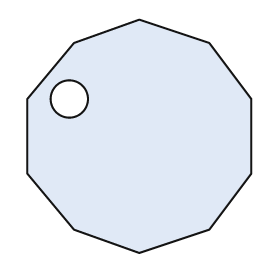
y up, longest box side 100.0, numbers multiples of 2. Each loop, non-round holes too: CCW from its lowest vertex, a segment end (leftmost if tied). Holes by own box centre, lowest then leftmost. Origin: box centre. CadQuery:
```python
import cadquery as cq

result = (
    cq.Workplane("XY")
    .moveTo(0.0, -50.0)
    .lineTo(30.0, -40.0)
    .lineTo(48.0, -16.0)
    .lineTo(48.0, 16.0)
    .lineTo(30.0, 40.0)
    .lineTo(0.0, 50.0)
    .lineTo(-28.0, 40.0)
    .lineTo(-48.0, 16.0)
    .lineTo(-48.0, -16.0)
    .lineTo(-28.0, -40.0)
    .close()
    .moveTo(-30.0, 16.0)
    .circle(8.0)
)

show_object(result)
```